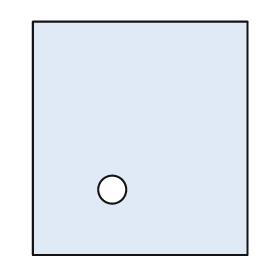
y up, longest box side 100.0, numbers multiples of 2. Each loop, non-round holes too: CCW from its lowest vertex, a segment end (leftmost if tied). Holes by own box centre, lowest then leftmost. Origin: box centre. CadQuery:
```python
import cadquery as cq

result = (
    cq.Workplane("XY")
    .moveTo(-46.0, -50.0)
    .lineTo(46.0, -50.0)
    .lineTo(46.0, 50.0)
    .lineTo(-46.0, 50.0)
    .close()
    .moveTo(-12.0, -22.0)
    .circle(6.0)
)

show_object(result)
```